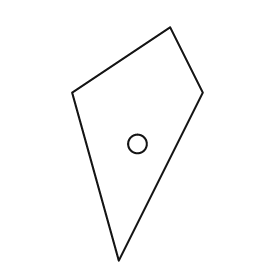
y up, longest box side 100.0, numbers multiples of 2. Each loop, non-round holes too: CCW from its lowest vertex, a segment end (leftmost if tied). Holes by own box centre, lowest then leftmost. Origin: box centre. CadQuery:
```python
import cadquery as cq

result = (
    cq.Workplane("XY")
    .moveTo(-8.0, -50.0)
    .lineTo(28.0, 22.0)
    .lineTo(14.0, 50.0)
    .lineTo(-28.0, 22.0)
    .close()
    .moveTo(0.0, 0.0)
    .circle(4.0)
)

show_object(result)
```